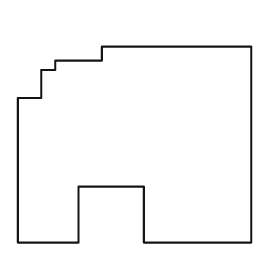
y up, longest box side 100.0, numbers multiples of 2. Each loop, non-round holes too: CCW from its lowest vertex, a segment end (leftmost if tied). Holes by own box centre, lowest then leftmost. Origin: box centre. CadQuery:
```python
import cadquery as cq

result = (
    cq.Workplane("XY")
    .moveTo(-50.0, -42.0)
    .lineTo(-24.0, -42.0)
    .lineTo(-24.0, -18.0)
    .lineTo(4.0, -18.0)
    .lineTo(4.0, -42.0)
    .lineTo(50.0, -42.0)
    .lineTo(50.0, 42.0)
    .lineTo(-14.0, 42.0)
    .lineTo(-14.0, 36.0)
    .lineTo(-34.0, 36.0)
    .lineTo(-34.0, 32.0)
    .lineTo(-40.0, 32.0)
    .lineTo(-40.0, 20.0)
    .lineTo(-50.0, 20.0)
    .close()
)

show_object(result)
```